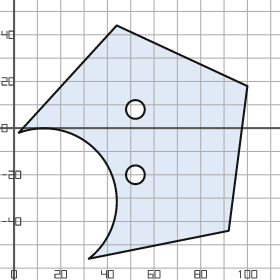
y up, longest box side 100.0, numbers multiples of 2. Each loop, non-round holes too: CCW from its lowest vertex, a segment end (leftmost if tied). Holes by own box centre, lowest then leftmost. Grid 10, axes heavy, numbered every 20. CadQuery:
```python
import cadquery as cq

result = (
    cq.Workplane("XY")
    .moveTo(32.0, -56.0)
    .lineTo(92.0, -44.0)
    .lineTo(100.0, 18.0)
    .lineTo(44.0, 44.0)
    .lineTo(2.0, -2.0)
    .threePointArc((40.0, -16.0), (32.0, -56.0))
    .close()
    .moveTo(52.0, -20.0)
    .circle(4.0)
    .moveTo(52.0, 8.0)
    .circle(4.0)
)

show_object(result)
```